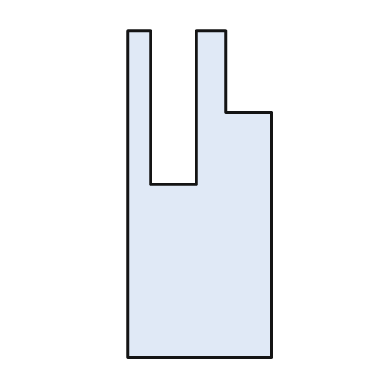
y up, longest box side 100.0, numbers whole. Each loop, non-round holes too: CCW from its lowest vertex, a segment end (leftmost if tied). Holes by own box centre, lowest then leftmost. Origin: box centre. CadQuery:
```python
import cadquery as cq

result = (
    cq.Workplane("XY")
    .moveTo(-22.0, -50.0)
    .lineTo(22.0, -50.0)
    .lineTo(22.0, 25.0)
    .lineTo(8.0, 25.0)
    .lineTo(8.0, 50.0)
    .lineTo(-1.0, 50.0)
    .lineTo(-1.0, 3.0)
    .lineTo(-15.0, 3.0)
    .lineTo(-15.0, 50.0)
    .lineTo(-22.0, 50.0)
    .close()
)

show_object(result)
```